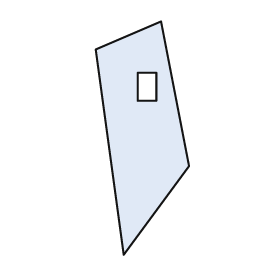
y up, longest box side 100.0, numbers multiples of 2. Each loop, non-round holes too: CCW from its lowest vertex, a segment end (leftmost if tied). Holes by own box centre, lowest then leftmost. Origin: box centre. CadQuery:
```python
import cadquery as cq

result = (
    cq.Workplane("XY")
    .moveTo(-8.0, -50.0)
    .lineTo(20.0, -12.0)
    .lineTo(8.0, 50.0)
    .lineTo(-20.0, 38.0)
    .close()
    .moveTo(-2.0, 16.0)
    .lineTo(6.0, 16.0)
    .lineTo(6.0, 28.0)
    .lineTo(-2.0, 28.0)
    .close()
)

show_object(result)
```